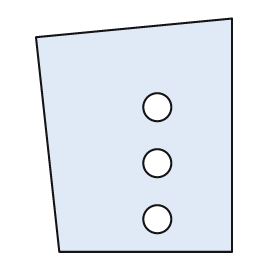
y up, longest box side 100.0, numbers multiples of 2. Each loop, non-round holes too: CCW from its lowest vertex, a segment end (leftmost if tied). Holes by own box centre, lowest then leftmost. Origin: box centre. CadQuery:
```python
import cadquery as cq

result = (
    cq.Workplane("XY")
    .moveTo(-32.0, -50.0)
    .lineTo(42.0, -50.0)
    .lineTo(42.0, 50.0)
    .lineTo(-42.0, 42.0)
    .close()
    .moveTo(10.0, -36.0)
    .circle(6.0)
    .moveTo(10.0, -12.0)
    .circle(6.0)
    .moveTo(10.0, 12.0)
    .circle(6.0)
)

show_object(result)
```